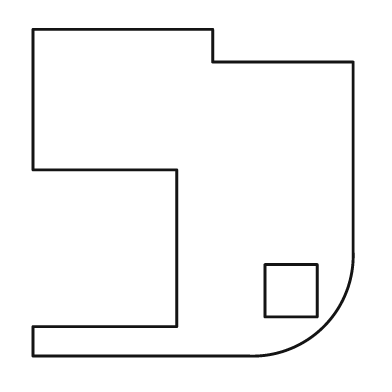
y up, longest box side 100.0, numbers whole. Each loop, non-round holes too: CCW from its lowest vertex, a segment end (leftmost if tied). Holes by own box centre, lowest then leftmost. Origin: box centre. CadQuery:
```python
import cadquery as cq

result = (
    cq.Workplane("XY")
    .moveTo(-49.0, -50.0)
    .lineTo(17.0, -50.0)
    .threePointArc((40.0, -41.0), (49.0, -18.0))
    .lineTo(49.0, 40.0)
    .lineTo(6.0, 40.0)
    .lineTo(6.0, 50.0)
    .lineTo(-49.0, 50.0)
    .lineTo(-49.0, 7.0)
    .lineTo(-5.0, 7.0)
    .lineTo(-5.0, -41.0)
    .lineTo(-49.0, -41.0)
    .close()
    .moveTo(22.0, -38.0)
    .lineTo(38.0, -38.0)
    .lineTo(38.0, -22.0)
    .lineTo(22.0, -22.0)
    .close()
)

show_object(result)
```